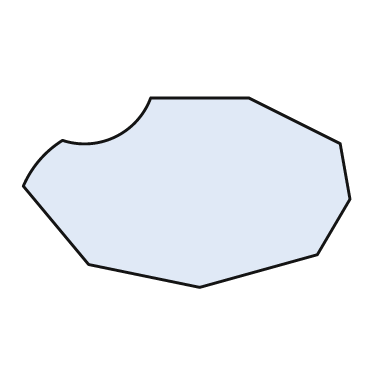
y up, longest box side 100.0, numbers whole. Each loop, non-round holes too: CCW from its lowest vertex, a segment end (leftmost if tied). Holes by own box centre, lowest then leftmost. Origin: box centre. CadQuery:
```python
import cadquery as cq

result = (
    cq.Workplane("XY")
    .moveTo(4.0, -29.0)
    .lineTo(40.0, -19.0)
    .lineTo(50.0, -2.0)
    .lineTo(47.0, 15.0)
    .lineTo(19.0, 29.0)
    .lineTo(-11.0, 29.0)
    .threePointArc((-22.0, 17.0), (-38.0, 16.0))
    .threePointArc((-45.0, 10.0), (-50.0, 2.0))
    .lineTo(-30.0, -22.0)
    .close()
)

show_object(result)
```